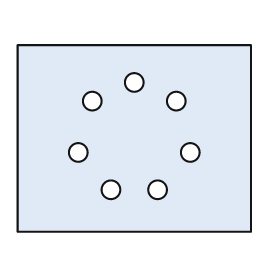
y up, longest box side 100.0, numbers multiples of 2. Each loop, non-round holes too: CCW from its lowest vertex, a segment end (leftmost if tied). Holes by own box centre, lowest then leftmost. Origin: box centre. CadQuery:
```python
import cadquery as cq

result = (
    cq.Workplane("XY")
    .moveTo(-50.0, -40.0)
    .lineTo(50.0, -40.0)
    .lineTo(50.0, 40.0)
    .lineTo(-50.0, 40.0)
    .close()
    .moveTo(-10.0, -22.0)
    .circle(4.0)
    .moveTo(10.0, -22.0)
    .circle(4.0)
    .moveTo(-24.0, -6.0)
    .circle(4.0)
    .moveTo(24.0, -6.0)
    .circle(4.0)
    .moveTo(-18.0, 16.0)
    .circle(4.0)
    .moveTo(18.0, 16.0)
    .circle(4.0)
    .moveTo(0.0, 24.0)
    .circle(4.0)
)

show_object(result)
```